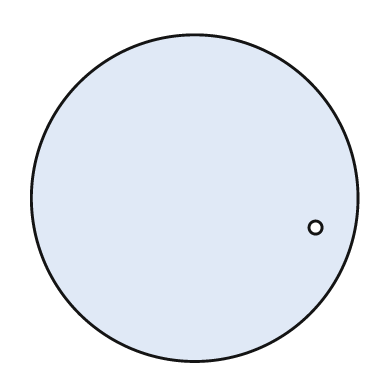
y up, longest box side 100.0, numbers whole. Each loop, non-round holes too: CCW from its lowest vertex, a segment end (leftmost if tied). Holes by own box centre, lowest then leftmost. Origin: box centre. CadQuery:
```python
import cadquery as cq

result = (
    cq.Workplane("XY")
    .moveTo(0.0, 0.0)
    .circle(50.0)
    .moveTo(37.0, -9.0)
    .circle(2.0)
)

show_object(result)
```